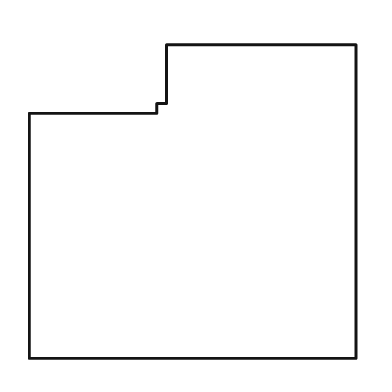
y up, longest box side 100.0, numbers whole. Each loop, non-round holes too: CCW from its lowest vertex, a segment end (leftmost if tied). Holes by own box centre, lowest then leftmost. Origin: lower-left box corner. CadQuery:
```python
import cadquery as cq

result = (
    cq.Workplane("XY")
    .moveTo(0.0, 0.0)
    .lineTo(100.0, 0.0)
    .lineTo(100.0, 96.0)
    .lineTo(42.0, 96.0)
    .lineTo(42.0, 78.0)
    .lineTo(39.0, 78.0)
    .lineTo(39.0, 75.0)
    .lineTo(0.0, 75.0)
    .close()
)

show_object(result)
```